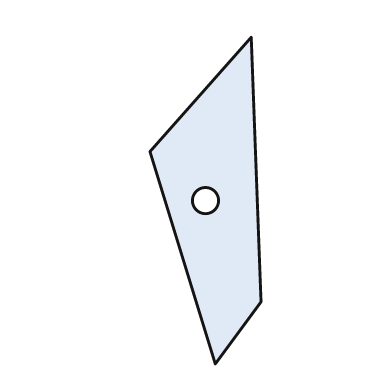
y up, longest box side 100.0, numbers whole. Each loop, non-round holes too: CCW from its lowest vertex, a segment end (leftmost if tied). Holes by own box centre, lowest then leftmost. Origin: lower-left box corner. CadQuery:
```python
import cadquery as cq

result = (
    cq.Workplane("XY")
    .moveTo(20.0, 0.0)
    .lineTo(34.0, 19.0)
    .lineTo(31.0, 100.0)
    .lineTo(0.0, 65.0)
    .close()
    .moveTo(17.0, 50.0)
    .circle(4.0)
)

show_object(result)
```